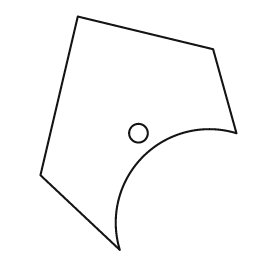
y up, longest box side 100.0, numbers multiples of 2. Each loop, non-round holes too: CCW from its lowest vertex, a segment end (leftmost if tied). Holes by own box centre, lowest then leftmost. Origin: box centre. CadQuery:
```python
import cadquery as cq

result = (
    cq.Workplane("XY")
    .moveTo(-8.0, -50.0)
    .threePointArc((2.0, -10.0), (42.0, 0.0))
    .lineTo(32.0, 36.0)
    .lineTo(-26.0, 50.0)
    .lineTo(-42.0, -18.0)
    .close()
    .moveTo(0.0, 0.0)
    .circle(4.0)
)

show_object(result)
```